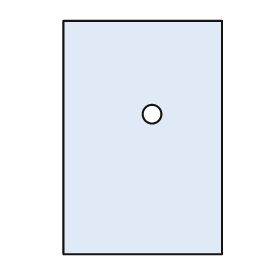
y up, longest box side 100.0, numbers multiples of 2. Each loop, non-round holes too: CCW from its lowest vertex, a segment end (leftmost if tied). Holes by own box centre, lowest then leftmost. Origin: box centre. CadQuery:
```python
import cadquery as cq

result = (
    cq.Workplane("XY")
    .moveTo(-34.0, -50.0)
    .lineTo(34.0, -50.0)
    .lineTo(34.0, 50.0)
    .lineTo(-34.0, 50.0)
    .close()
    .moveTo(4.0, 10.0)
    .circle(4.0)
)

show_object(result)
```